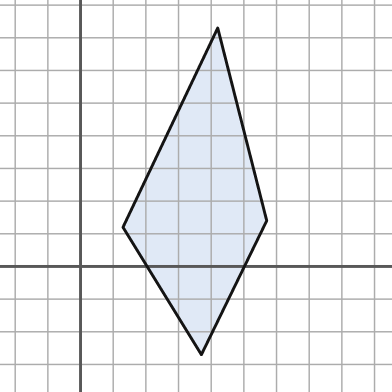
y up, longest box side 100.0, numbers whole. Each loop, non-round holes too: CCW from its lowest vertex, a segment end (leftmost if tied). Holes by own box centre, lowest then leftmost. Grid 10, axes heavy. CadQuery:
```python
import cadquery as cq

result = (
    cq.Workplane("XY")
    .moveTo(37.0, -27.0)
    .lineTo(57.0, 14.0)
    .lineTo(42.0, 73.0)
    .lineTo(13.0, 12.0)
    .close()
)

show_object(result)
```